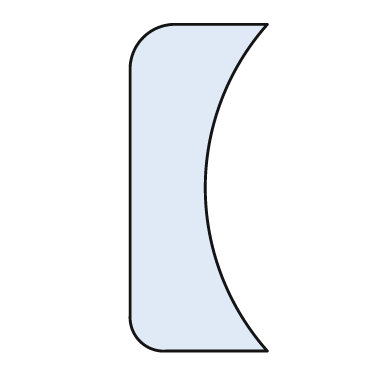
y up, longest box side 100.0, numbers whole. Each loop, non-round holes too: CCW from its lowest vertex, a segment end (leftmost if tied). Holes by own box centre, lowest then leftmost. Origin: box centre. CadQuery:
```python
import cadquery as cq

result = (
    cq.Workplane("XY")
    .moveTo(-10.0, -50.0)
    .lineTo(21.0, -50.0)
    .threePointArc((2.0, 0.0), (21.0, 50.0))
    .lineTo(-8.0, 50.0)
    .threePointArc((-17.0, 46.0), (-21.0, 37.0))
    .lineTo(-21.0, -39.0)
    .threePointArc((-18.0, -47.0), (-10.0, -50.0))
    .close()
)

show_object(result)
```